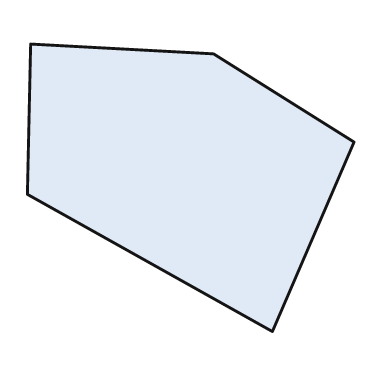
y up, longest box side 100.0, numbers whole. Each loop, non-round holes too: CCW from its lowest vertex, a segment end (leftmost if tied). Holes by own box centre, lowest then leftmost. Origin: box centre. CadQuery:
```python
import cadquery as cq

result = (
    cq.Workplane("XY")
    .moveTo(25.0, -44.0)
    .lineTo(50.0, 14.0)
    .lineTo(7.0, 41.0)
    .lineTo(-49.0, 44.0)
    .lineTo(-50.0, -2.0)
    .close()
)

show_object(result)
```